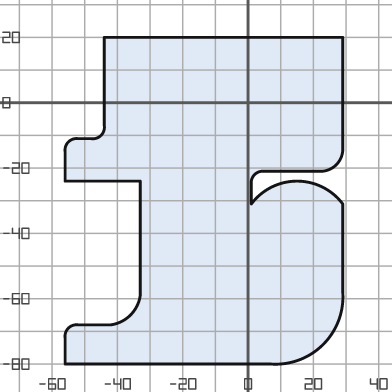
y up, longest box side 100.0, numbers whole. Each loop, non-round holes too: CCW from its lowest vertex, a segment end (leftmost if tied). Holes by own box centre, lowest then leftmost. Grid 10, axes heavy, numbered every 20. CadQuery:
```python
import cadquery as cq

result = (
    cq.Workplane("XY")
    .moveTo(-56.0, -80.0)
    .lineTo(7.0, -80.0)
    .threePointArc((23.0, -74.0), (29.0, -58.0))
    .lineTo(29.0, -31.0)
    .threePointArc((15.0, -24.0), (1.0, -31.0))
    .lineTo(1.0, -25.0)
    .threePointArc((2.0, -22.0), (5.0, -21.0))
    .lineTo(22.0, -21.0)
    .threePointArc((27.0, -19.0), (29.0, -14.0))
    .lineTo(29.0, 20.0)
    .lineTo(-44.0, 20.0)
    .lineTo(-44.0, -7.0)
    .threePointArc((-45.0, -10.0), (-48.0, -11.0))
    .lineTo(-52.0, -11.0)
    .threePointArc((-55.0, -12.0), (-56.0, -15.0))
    .lineTo(-56.0, -24.0)
    .lineTo(-33.0, -24.0)
    .lineTo(-33.0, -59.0)
    .threePointArc((-36.0, -65.0), (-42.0, -68.0))
    .lineTo(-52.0, -68.0)
    .threePointArc((-55.0, -69.0), (-56.0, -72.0))
    .close()
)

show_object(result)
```